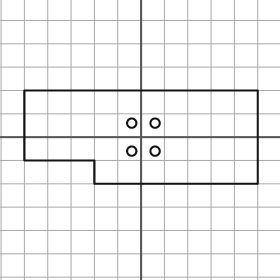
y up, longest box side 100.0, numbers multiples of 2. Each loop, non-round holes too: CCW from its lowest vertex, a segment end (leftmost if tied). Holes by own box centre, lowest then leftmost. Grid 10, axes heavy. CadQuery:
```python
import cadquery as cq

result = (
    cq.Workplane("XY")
    .moveTo(-20.0, -20.0)
    .lineTo(50.0, -20.0)
    .lineTo(50.0, 20.0)
    .lineTo(-50.0, 20.0)
    .lineTo(-50.0, -10.0)
    .lineTo(-20.0, -10.0)
    .close()
    .moveTo(-4.0, -6.0)
    .circle(2.0)
    .moveTo(6.0, -6.0)
    .circle(2.0)
    .moveTo(-4.0, 6.0)
    .circle(2.0)
    .moveTo(6.0, 6.0)
    .circle(2.0)
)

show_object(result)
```